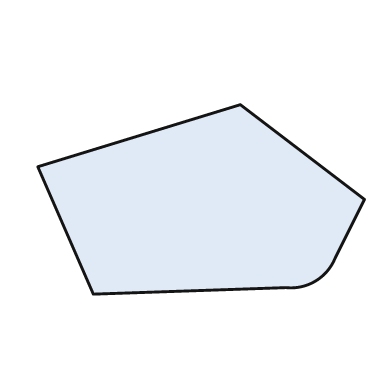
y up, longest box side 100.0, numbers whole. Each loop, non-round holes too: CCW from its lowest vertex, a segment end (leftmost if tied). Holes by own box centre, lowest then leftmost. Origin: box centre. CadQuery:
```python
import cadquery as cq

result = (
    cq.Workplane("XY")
    .moveTo(-33.0, -29.0)
    .lineTo(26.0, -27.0)
    .threePointArc((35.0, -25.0), (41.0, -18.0))
    .lineTo(50.0, 0.0)
    .lineTo(12.0, 29.0)
    .lineTo(-50.0, 10.0)
    .close()
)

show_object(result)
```